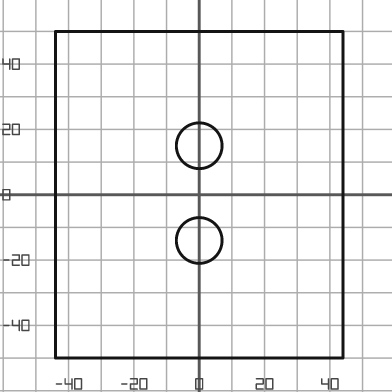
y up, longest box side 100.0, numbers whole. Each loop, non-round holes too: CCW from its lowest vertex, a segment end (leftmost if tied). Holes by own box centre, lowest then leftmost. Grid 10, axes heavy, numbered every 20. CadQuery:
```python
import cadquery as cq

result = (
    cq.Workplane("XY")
    .moveTo(-44.0, -50.0)
    .lineTo(44.0, -50.0)
    .lineTo(44.0, 50.0)
    .lineTo(-44.0, 50.0)
    .close()
    .moveTo(0.0, -14.0)
    .circle(7.0)
    .moveTo(0.0, 15.0)
    .circle(7.0)
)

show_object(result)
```